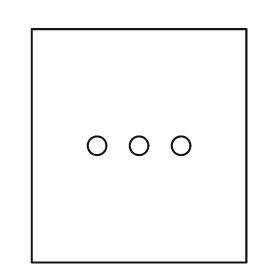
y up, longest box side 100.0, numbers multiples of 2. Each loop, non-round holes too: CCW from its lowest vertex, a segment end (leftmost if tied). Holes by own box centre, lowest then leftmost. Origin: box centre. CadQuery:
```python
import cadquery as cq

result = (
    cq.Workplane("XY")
    .moveTo(-46.0, -50.0)
    .lineTo(46.0, -50.0)
    .lineTo(46.0, 50.0)
    .lineTo(-46.0, 50.0)
    .close()
    .moveTo(-18.0, 0.0)
    .circle(4.0)
    .moveTo(0.0, 0.0)
    .circle(4.0)
    .moveTo(18.0, 0.0)
    .circle(4.0)
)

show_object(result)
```